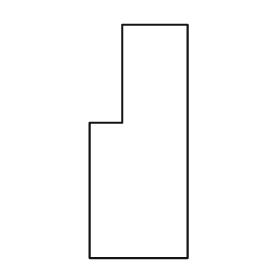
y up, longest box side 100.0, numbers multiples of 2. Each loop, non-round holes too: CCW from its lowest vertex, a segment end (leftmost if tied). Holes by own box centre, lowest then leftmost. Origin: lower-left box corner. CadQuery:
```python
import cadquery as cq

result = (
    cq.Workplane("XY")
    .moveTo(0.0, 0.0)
    .lineTo(42.0, 0.0)
    .lineTo(42.0, 100.0)
    .lineTo(14.0, 100.0)
    .lineTo(14.0, 58.0)
    .lineTo(0.0, 58.0)
    .close()
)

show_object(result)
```